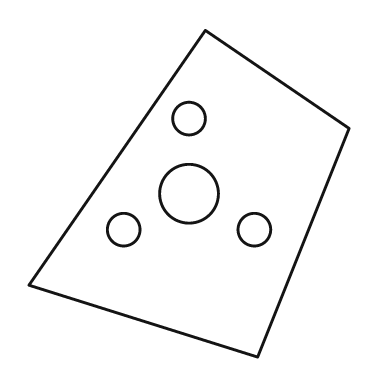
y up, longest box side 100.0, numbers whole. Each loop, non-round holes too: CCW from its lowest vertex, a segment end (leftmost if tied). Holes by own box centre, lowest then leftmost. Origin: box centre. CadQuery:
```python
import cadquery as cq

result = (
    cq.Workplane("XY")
    .moveTo(21.0, -50.0)
    .lineTo(49.0, 20.0)
    .lineTo(5.0, 50.0)
    .lineTo(-49.0, -28.0)
    .close()
    .moveTo(-20.0, -11.0)
    .circle(5.0)
    .moveTo(20.0, -11.0)
    .circle(5.0)
    .moveTo(0.0, 0.0)
    .circle(9.0)
    .moveTo(0.0, 23.0)
    .circle(5.0)
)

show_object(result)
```